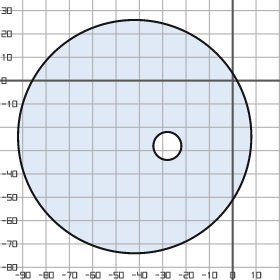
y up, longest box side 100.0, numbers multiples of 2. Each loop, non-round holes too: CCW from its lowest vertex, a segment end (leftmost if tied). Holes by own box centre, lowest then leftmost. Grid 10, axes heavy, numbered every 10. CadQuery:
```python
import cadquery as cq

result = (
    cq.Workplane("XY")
    .moveTo(-42.0, -24.0)
    .circle(50.0)
    .moveTo(-28.0, -28.0)
    .circle(6.0)
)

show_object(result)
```